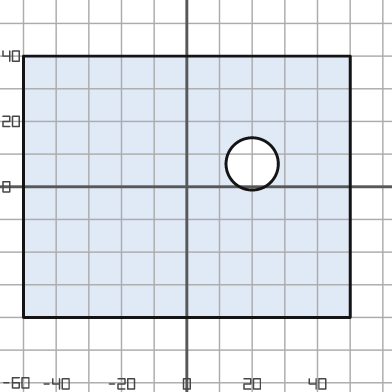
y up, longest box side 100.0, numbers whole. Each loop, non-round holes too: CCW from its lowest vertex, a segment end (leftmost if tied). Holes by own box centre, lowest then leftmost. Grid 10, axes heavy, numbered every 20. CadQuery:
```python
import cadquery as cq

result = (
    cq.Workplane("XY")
    .moveTo(-50.0, -40.0)
    .lineTo(50.0, -40.0)
    .lineTo(50.0, 40.0)
    .lineTo(-50.0, 40.0)
    .close()
    .moveTo(20.0, 7.0)
    .circle(8.0)
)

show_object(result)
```